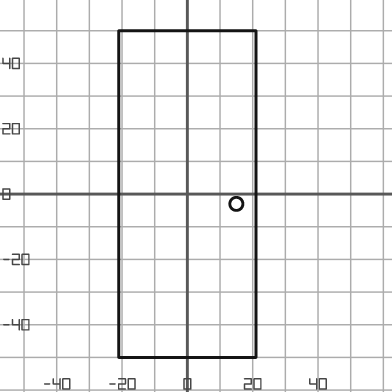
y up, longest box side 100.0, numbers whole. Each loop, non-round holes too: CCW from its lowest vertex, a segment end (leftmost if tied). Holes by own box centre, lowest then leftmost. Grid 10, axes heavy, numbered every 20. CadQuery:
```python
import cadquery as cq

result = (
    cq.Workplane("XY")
    .moveTo(-21.0, -50.0)
    .lineTo(21.0, -50.0)
    .lineTo(21.0, 50.0)
    .lineTo(-21.0, 50.0)
    .close()
    .moveTo(15.0, -3.0)
    .circle(2.0)
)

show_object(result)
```